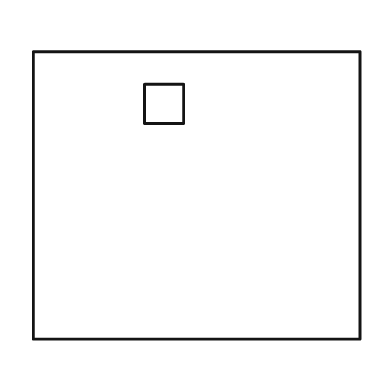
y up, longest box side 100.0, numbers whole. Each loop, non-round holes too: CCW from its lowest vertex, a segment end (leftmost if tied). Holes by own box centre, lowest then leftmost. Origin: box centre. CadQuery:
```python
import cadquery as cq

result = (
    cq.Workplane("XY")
    .moveTo(-50.0, -44.0)
    .lineTo(50.0, -44.0)
    .lineTo(50.0, 44.0)
    .lineTo(-50.0, 44.0)
    .close()
    .moveTo(-16.0, 22.0)
    .lineTo(-4.0, 22.0)
    .lineTo(-4.0, 34.0)
    .lineTo(-16.0, 34.0)
    .close()
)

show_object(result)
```